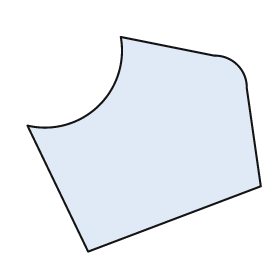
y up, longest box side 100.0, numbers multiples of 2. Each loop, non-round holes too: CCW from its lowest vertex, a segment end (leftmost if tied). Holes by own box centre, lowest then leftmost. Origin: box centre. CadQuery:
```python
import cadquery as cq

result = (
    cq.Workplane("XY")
    .moveTo(-24.0, -46.0)
    .lineTo(50.0, -18.0)
    .lineTo(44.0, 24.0)
    .threePointArc((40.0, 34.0), (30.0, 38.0))
    .lineTo(-10.0, 46.0)
    .threePointArc((-20.0, 16.0), (-50.0, 8.0))
    .close()
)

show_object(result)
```